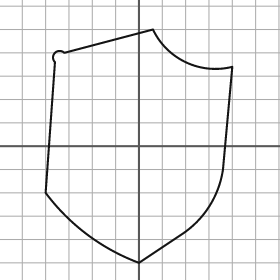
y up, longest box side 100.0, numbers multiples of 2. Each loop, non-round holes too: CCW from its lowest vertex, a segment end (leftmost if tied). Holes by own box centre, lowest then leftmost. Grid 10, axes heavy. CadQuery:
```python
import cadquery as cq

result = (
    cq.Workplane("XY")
    .moveTo(0.0, -50.0)
    .lineTo(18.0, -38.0)
    .threePointArc((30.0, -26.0), (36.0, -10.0))
    .lineTo(40.0, 34.0)
    .threePointArc((20.0, 36.0), (6.0, 50.0))
    .lineTo(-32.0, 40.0)
    .threePointArc((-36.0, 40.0), (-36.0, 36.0))
    .lineTo(-40.0, -20.0)
    .threePointArc((-22.0, -38.0), (0.0, -50.0))
    .close()
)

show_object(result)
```